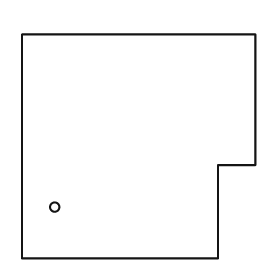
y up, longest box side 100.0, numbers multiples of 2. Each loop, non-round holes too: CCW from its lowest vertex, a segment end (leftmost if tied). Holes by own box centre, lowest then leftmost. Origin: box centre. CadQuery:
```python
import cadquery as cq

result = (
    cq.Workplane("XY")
    .moveTo(-50.0, -48.0)
    .lineTo(34.0, -48.0)
    .lineTo(34.0, -8.0)
    .lineTo(50.0, -8.0)
    .lineTo(50.0, 48.0)
    .lineTo(-50.0, 48.0)
    .close()
    .moveTo(-36.0, -26.0)
    .circle(2.0)
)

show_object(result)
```